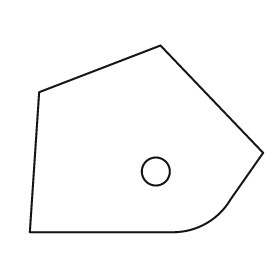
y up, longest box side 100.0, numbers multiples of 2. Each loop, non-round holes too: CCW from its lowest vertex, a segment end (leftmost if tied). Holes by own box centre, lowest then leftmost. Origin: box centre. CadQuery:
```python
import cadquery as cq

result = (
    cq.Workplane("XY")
    .moveTo(-50.0, -40.0)
    .lineTo(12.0, -40.0)
    .threePointArc((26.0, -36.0), (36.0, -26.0))
    .lineTo(50.0, -6.0)
    .lineTo(6.0, 40.0)
    .lineTo(-46.0, 20.0)
    .close()
    .moveTo(4.0, -14.0)
    .circle(6.0)
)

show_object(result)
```